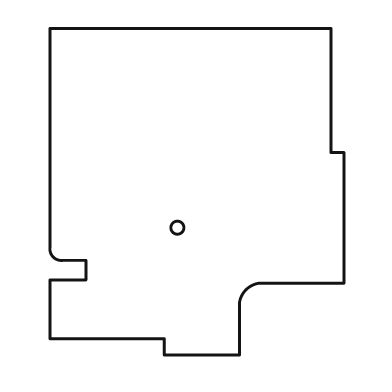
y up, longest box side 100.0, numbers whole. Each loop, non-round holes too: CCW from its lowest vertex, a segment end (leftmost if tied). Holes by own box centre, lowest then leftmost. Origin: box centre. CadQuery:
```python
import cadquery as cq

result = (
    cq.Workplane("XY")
    .moveTo(-10.0, -50.0)
    .lineTo(13.0, -50.0)
    .lineTo(13.0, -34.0)
    .threePointArc((15.0, -30.0), (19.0, -28.0))
    .lineTo(45.0, -28.0)
    .lineTo(45.0, 12.0)
    .lineTo(41.0, 12.0)
    .lineTo(41.0, 50.0)
    .lineTo(-45.0, 50.0)
    .lineTo(-45.0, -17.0)
    .threePointArc((-44.0, -20.0), (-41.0, -21.0))
    .lineTo(-34.0, -21.0)
    .lineTo(-34.0, -27.0)
    .lineTo(-45.0, -27.0)
    .lineTo(-45.0, -45.0)
    .lineTo(-10.0, -45.0)
    .close()
    .moveTo(-6.0, -11.0)
    .circle(2.0)
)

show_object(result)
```